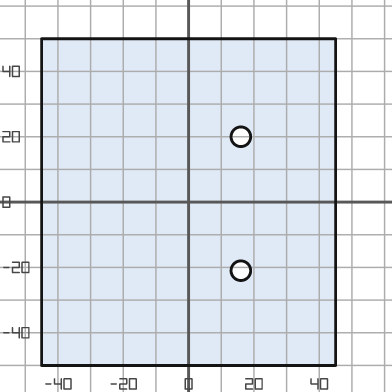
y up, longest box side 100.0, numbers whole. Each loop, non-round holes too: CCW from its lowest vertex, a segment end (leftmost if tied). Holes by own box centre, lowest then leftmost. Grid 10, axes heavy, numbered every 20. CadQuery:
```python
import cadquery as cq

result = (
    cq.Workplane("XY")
    .moveTo(-45.0, -50.0)
    .lineTo(45.0, -50.0)
    .lineTo(45.0, 50.0)
    .lineTo(-45.0, 50.0)
    .close()
    .moveTo(16.0, -21.0)
    .circle(3.0)
    .moveTo(16.0, 20.0)
    .circle(3.0)
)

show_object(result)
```